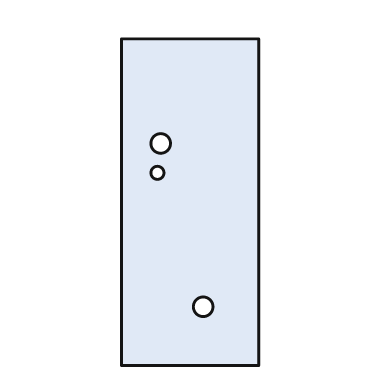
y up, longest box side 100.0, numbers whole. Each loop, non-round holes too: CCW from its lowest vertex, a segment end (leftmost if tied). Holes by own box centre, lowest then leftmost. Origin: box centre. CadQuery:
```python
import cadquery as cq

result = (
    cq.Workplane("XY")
    .moveTo(-21.0, -50.0)
    .lineTo(21.0, -50.0)
    .lineTo(21.0, 50.0)
    .lineTo(-21.0, 50.0)
    .close()
    .moveTo(4.0, -32.0)
    .circle(3.0)
    .moveTo(-10.0, 9.0)
    .circle(2.0)
    .moveTo(-9.0, 18.0)
    .circle(3.0)
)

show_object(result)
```